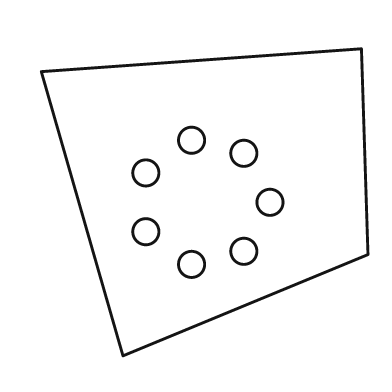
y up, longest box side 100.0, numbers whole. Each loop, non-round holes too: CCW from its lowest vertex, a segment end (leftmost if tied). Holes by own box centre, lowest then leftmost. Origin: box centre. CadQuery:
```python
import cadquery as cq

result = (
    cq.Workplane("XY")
    .moveTo(-25.0, -47.0)
    .lineTo(50.0, -16.0)
    .lineTo(48.0, 47.0)
    .lineTo(-50.0, 40.0)
    .close()
    .moveTo(-4.0, -19.0)
    .circle(4.0)
    .moveTo(12.0, -15.0)
    .circle(4.0)
    .moveTo(-18.0, -9.0)
    .circle(4.0)
    .moveTo(20.0, 0.0)
    .circle(4.0)
    .moveTo(-18.0, 9.0)
    .circle(4.0)
    .moveTo(12.0, 15.0)
    .circle(4.0)
    .moveTo(-4.0, 19.0)
    .circle(4.0)
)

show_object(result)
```